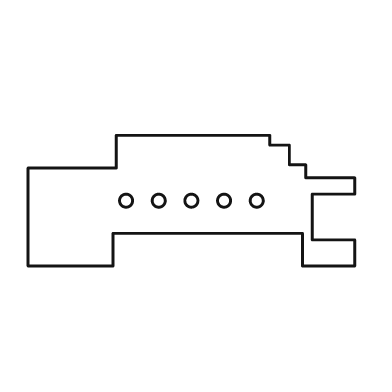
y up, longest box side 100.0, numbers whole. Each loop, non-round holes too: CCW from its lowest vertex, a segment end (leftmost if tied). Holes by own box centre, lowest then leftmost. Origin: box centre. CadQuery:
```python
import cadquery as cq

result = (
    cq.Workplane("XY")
    .moveTo(-50.0, -20.0)
    .lineTo(-24.0, -20.0)
    .lineTo(-24.0, -10.0)
    .lineTo(34.0, -10.0)
    .lineTo(34.0, -20.0)
    .lineTo(50.0, -20.0)
    .lineTo(50.0, -12.0)
    .lineTo(37.0, -12.0)
    .lineTo(37.0, 2.0)
    .lineTo(50.0, 2.0)
    .lineTo(50.0, 7.0)
    .lineTo(35.0, 7.0)
    .lineTo(35.0, 11.0)
    .lineTo(30.0, 11.0)
    .lineTo(30.0, 17.0)
    .lineTo(24.0, 17.0)
    .lineTo(24.0, 20.0)
    .lineTo(-23.0, 20.0)
    .lineTo(-23.0, 10.0)
    .lineTo(-50.0, 10.0)
    .close()
    .moveTo(-20.0, 0.0)
    .circle(2.0)
    .moveTo(-10.0, 0.0)
    .circle(2.0)
    .moveTo(0.0, 0.0)
    .circle(2.0)
    .moveTo(10.0, 0.0)
    .circle(2.0)
    .moveTo(20.0, 0.0)
    .circle(2.0)
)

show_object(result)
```